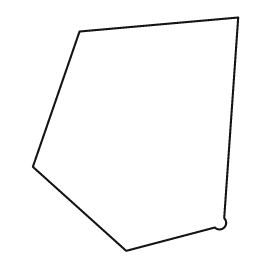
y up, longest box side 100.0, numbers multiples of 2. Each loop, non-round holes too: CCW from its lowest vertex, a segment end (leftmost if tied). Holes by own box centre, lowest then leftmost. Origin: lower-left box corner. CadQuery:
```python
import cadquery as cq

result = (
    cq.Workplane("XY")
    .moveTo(40.0, 0.0)
    .lineTo(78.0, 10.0)
    .threePointArc((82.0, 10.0), (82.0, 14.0))
    .lineTo(88.0, 100.0)
    .lineTo(20.0, 94.0)
    .lineTo(0.0, 36.0)
    .close()
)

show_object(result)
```